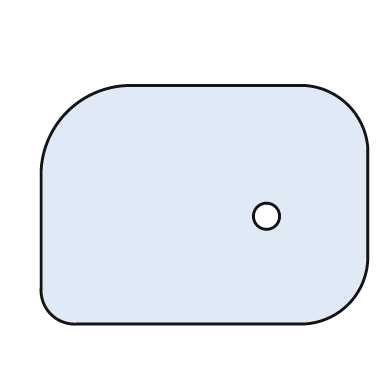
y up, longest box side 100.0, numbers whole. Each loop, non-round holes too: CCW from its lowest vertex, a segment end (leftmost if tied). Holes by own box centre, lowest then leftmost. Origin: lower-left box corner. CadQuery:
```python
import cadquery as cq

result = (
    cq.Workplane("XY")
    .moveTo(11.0, 0.0)
    .lineTo(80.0, 0.0)
    .threePointArc((94.0, 6.0), (100.0, 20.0))
    .lineTo(100.0, 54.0)
    .threePointArc((94.0, 67.0), (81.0, 73.0))
    .lineTo(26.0, 73.0)
    .threePointArc((8.0, 65.0), (0.0, 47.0))
    .lineTo(0.0, 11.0)
    .threePointArc((3.0, 3.0), (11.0, 0.0))
    .close()
    .moveTo(69.0, 33.0)
    .circle(4.0)
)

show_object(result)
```